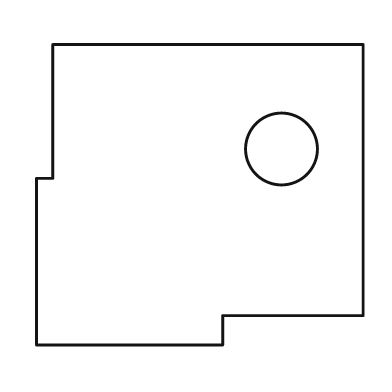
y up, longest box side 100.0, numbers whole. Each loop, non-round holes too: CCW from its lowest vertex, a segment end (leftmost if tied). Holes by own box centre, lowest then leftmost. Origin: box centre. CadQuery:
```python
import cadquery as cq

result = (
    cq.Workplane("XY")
    .moveTo(-50.0, -46.0)
    .lineTo(7.0, -46.0)
    .lineTo(7.0, -37.0)
    .lineTo(50.0, -37.0)
    .lineTo(50.0, 46.0)
    .lineTo(-45.0, 46.0)
    .lineTo(-45.0, 5.0)
    .lineTo(-50.0, 5.0)
    .close()
    .moveTo(25.0, 14.0)
    .circle(11.0)
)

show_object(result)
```